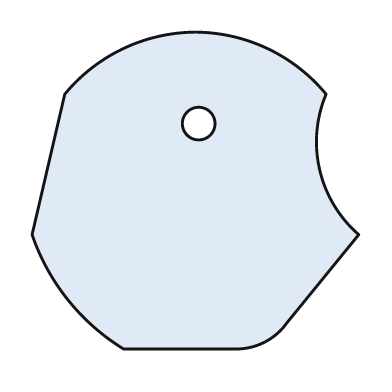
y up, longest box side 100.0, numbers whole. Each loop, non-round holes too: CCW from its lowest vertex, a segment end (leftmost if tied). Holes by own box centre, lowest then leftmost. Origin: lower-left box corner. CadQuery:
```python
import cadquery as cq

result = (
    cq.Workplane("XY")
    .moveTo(28.0, 0.0)
    .lineTo(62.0, 0.0)
    .threePointArc((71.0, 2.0), (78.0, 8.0))
    .lineTo(100.0, 35.0)
    .threePointArc((88.0, 55.0), (90.0, 78.0))
    .threePointArc((72.0, 92.0), (50.0, 97.0))
    .threePointArc((28.0, 92.0), (10.0, 78.0))
    .lineTo(0.0, 35.0)
    .threePointArc((11.0, 15.0), (28.0, 0.0))
    .close()
    .moveTo(51.0, 69.0)
    .circle(5.0)
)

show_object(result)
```